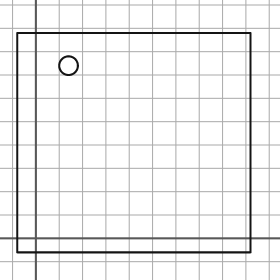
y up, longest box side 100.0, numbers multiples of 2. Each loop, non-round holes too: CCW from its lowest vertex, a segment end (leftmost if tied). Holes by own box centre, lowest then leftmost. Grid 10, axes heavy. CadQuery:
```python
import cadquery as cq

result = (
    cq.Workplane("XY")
    .moveTo(-8.0, -6.0)
    .lineTo(92.0, -6.0)
    .lineTo(92.0, 88.0)
    .lineTo(-8.0, 88.0)
    .close()
    .moveTo(14.0, 74.0)
    .circle(4.0)
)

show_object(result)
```